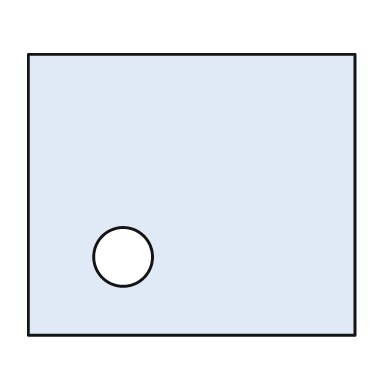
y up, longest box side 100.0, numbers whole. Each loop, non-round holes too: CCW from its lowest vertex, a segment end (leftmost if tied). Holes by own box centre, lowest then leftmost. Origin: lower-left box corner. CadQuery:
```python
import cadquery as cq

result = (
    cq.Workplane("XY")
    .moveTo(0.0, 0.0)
    .lineTo(100.0, 0.0)
    .lineTo(100.0, 86.0)
    .lineTo(0.0, 86.0)
    .close()
    .moveTo(29.0, 24.0)
    .circle(9.0)
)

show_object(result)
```